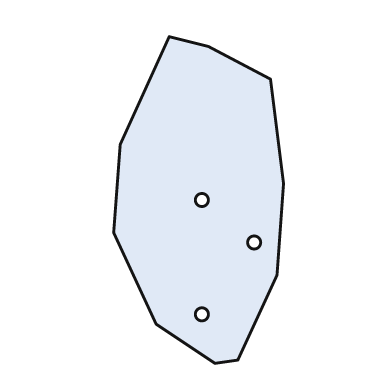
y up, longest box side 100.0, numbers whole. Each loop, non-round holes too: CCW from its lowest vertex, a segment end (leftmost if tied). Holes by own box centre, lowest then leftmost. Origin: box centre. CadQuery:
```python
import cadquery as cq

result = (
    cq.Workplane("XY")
    .moveTo(5.0, -50.0)
    .lineTo(12.0, -49.0)
    .lineTo(24.0, -23.0)
    .lineTo(26.0, 5.0)
    .lineTo(22.0, 37.0)
    .lineTo(3.0, 47.0)
    .lineTo(-9.0, 50.0)
    .lineTo(-24.0, 17.0)
    .lineTo(-26.0, -10.0)
    .lineTo(-13.0, -38.0)
    .close()
    .moveTo(1.0, -35.0)
    .circle(2.0)
    .moveTo(17.0, -13.0)
    .circle(2.0)
    .moveTo(1.0, 0.0)
    .circle(2.0)
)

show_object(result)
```